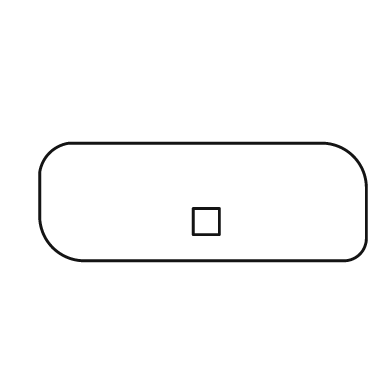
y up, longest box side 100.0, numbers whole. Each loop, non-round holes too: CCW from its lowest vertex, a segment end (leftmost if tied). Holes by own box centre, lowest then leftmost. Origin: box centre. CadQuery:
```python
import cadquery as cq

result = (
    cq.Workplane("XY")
    .moveTo(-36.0, -18.0)
    .lineTo(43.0, -18.0)
    .threePointArc((48.0, -16.0), (50.0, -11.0))
    .lineTo(50.0, 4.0)
    .threePointArc((46.0, 14.0), (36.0, 18.0))
    .lineTo(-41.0, 18.0)
    .threePointArc((-47.0, 15.0), (-50.0, 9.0))
    .lineTo(-50.0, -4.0)
    .threePointArc((-46.0, -14.0), (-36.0, -18.0))
    .close()
    .moveTo(-3.0, -10.0)
    .lineTo(5.0, -10.0)
    .lineTo(5.0, -2.0)
    .lineTo(-3.0, -2.0)
    .close()
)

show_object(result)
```